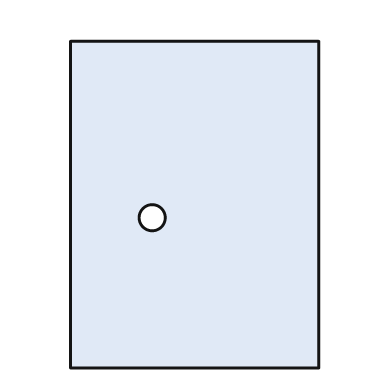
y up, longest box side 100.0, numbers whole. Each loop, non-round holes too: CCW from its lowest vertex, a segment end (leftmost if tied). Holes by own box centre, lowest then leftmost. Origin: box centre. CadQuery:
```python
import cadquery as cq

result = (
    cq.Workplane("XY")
    .moveTo(-38.0, -50.0)
    .lineTo(38.0, -50.0)
    .lineTo(38.0, 50.0)
    .lineTo(-38.0, 50.0)
    .close()
    .moveTo(-13.0, -4.0)
    .circle(4.0)
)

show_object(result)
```